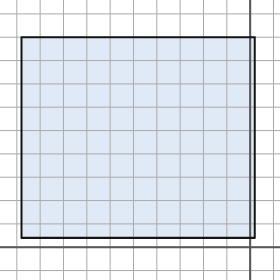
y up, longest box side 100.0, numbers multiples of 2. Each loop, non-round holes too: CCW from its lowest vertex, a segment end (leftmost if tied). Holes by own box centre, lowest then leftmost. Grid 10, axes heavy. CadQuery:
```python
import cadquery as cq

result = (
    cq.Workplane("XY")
    .moveTo(-98.0, 4.0)
    .lineTo(2.0, 4.0)
    .lineTo(2.0, 90.0)
    .lineTo(-98.0, 90.0)
    .close()
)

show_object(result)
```